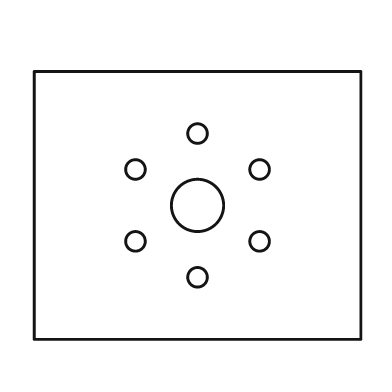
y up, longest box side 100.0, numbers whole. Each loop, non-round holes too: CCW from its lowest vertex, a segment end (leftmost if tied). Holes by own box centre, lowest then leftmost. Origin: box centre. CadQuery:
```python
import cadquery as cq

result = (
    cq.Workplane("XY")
    .moveTo(-50.0, -41.0)
    .lineTo(50.0, -41.0)
    .lineTo(50.0, 41.0)
    .lineTo(-50.0, 41.0)
    .close()
    .moveTo(0.0, -22.0)
    .circle(3.0)
    .moveTo(-19.0, -11.0)
    .circle(3.0)
    .moveTo(19.0, -11.0)
    .circle(3.0)
    .moveTo(0.0, 0.0)
    .circle(8.0)
    .moveTo(-19.0, 11.0)
    .circle(3.0)
    .moveTo(19.0, 11.0)
    .circle(3.0)
    .moveTo(0.0, 22.0)
    .circle(3.0)
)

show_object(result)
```